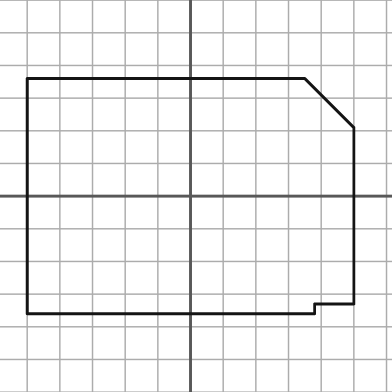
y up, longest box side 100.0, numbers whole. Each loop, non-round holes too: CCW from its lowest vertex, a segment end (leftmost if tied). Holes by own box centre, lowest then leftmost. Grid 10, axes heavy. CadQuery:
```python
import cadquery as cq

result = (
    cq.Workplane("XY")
    .moveTo(-50.0, -36.0)
    .lineTo(38.0, -36.0)
    .lineTo(38.0, -33.0)
    .lineTo(50.0, -33.0)
    .lineTo(50.0, 21.0)
    .lineTo(35.0, 36.0)
    .lineTo(-50.0, 36.0)
    .close()
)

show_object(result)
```